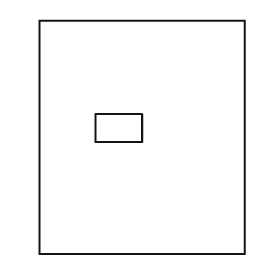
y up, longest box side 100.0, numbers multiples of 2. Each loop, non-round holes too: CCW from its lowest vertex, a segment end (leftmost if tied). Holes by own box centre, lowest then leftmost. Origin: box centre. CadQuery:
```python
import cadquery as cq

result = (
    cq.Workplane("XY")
    .moveTo(-44.0, -50.0)
    .lineTo(44.0, -50.0)
    .lineTo(44.0, 50.0)
    .lineTo(-44.0, 50.0)
    .close()
    .moveTo(-20.0, -2.0)
    .lineTo(0.0, -2.0)
    .lineTo(0.0, 10.0)
    .lineTo(-20.0, 10.0)
    .close()
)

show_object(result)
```